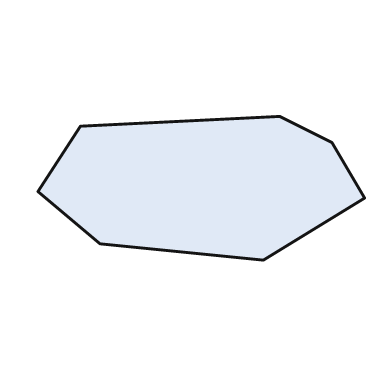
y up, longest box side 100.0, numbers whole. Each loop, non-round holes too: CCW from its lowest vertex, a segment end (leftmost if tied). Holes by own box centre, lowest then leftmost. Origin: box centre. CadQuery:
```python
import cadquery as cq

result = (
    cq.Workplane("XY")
    .moveTo(19.0, -22.0)
    .lineTo(50.0, -3.0)
    .lineTo(40.0, 14.0)
    .lineTo(24.0, 22.0)
    .lineTo(-37.0, 19.0)
    .lineTo(-50.0, -1.0)
    .lineTo(-31.0, -17.0)
    .close()
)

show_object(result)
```